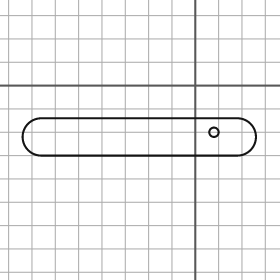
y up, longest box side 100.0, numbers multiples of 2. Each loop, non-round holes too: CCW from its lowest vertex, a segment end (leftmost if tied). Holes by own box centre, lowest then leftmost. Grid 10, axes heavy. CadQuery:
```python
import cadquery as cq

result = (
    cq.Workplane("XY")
    .moveTo(-66.0, -30.0)
    .lineTo(18.0, -30.0)
    .threePointArc((26.0, -22.0), (18.0, -14.0))
    .lineTo(-66.0, -14.0)
    .threePointArc((-74.0, -22.0), (-66.0, -30.0))
    .close()
    .moveTo(8.0, -20.0)
    .circle(2.0)
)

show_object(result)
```